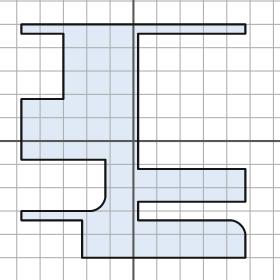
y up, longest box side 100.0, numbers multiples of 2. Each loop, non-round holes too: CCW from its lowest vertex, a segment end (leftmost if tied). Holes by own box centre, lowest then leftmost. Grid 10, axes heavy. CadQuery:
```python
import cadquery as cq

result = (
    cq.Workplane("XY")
    .moveTo(-22.0, -50.0)
    .lineTo(48.0, -50.0)
    .lineTo(48.0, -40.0)
    .threePointArc((46.0, -36.0), (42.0, -34.0))
    .lineTo(2.0, -34.0)
    .lineTo(2.0, -26.0)
    .lineTo(48.0, -26.0)
    .lineTo(48.0, -12.0)
    .lineTo(2.0, -12.0)
    .lineTo(2.0, 46.0)
    .lineTo(48.0, 46.0)
    .lineTo(48.0, 50.0)
    .lineTo(-48.0, 50.0)
    .lineTo(-48.0, 46.0)
    .lineTo(-30.0, 46.0)
    .lineTo(-30.0, 18.0)
    .lineTo(-48.0, 18.0)
    .lineTo(-48.0, -8.0)
    .lineTo(-12.0, -8.0)
    .lineTo(-12.0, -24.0)
    .threePointArc((-14.0, -28.0), (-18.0, -30.0))
    .lineTo(-48.0, -30.0)
    .lineTo(-48.0, -34.0)
    .lineTo(-22.0, -34.0)
    .close()
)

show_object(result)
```